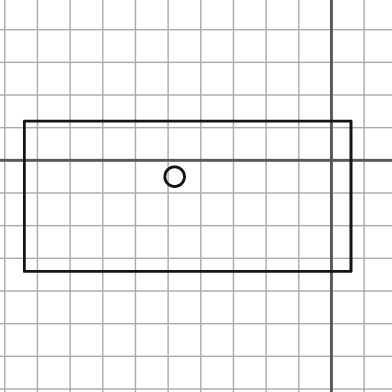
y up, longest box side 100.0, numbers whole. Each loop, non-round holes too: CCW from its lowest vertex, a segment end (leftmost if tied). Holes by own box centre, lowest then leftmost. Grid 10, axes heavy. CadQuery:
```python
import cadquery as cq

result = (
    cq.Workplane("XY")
    .moveTo(-94.0, -34.0)
    .lineTo(6.0, -34.0)
    .lineTo(6.0, 12.0)
    .lineTo(-94.0, 12.0)
    .close()
    .moveTo(-48.0, -5.0)
    .circle(3.0)
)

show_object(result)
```